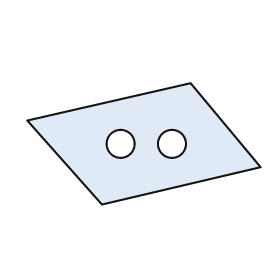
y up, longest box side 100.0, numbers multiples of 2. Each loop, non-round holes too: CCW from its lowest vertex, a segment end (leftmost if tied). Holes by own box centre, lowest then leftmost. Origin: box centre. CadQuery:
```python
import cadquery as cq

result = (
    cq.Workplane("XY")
    .moveTo(-18.0, -26.0)
    .lineTo(50.0, -10.0)
    .lineTo(20.0, 26.0)
    .lineTo(-50.0, 10.0)
    .close()
    .moveTo(-10.0, 0.0)
    .circle(6.0)
    .moveTo(12.0, 0.0)
    .circle(6.0)
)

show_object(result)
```